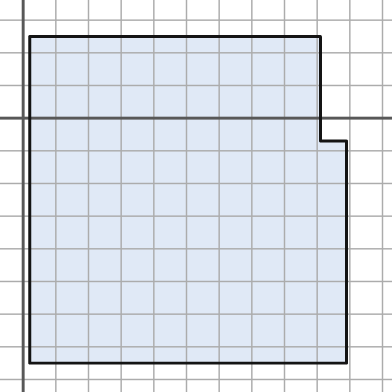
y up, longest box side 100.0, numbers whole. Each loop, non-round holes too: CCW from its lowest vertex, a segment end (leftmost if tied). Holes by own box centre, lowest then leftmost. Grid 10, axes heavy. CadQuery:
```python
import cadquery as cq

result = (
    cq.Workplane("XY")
    .moveTo(2.0, -75.0)
    .lineTo(99.0, -75.0)
    .lineTo(99.0, -7.0)
    .lineTo(91.0, -7.0)
    .lineTo(91.0, 25.0)
    .lineTo(2.0, 25.0)
    .close()
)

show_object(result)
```